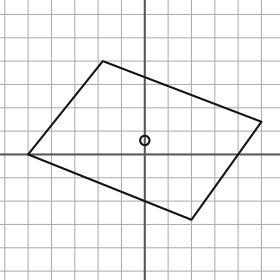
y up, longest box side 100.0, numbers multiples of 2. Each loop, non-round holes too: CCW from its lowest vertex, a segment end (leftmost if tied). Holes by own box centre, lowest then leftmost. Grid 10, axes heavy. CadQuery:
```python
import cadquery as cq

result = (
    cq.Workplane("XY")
    .moveTo(20.0, -28.0)
    .lineTo(50.0, 14.0)
    .lineTo(-18.0, 40.0)
    .lineTo(-50.0, 0.0)
    .close()
    .moveTo(0.0, 6.0)
    .circle(2.0)
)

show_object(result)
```